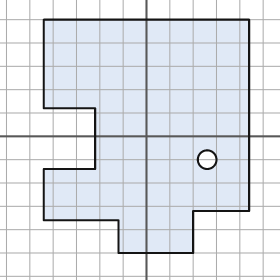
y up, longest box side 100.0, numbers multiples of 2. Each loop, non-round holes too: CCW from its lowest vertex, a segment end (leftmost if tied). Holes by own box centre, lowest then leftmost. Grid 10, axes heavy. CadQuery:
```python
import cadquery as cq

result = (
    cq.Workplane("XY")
    .moveTo(-12.0, -50.0)
    .lineTo(20.0, -50.0)
    .lineTo(20.0, -32.0)
    .lineTo(44.0, -32.0)
    .lineTo(44.0, 50.0)
    .lineTo(-44.0, 50.0)
    .lineTo(-44.0, 12.0)
    .lineTo(-22.0, 12.0)
    .lineTo(-22.0, -14.0)
    .lineTo(-44.0, -14.0)
    .lineTo(-44.0, -36.0)
    .lineTo(-12.0, -36.0)
    .close()
    .moveTo(26.0, -10.0)
    .circle(4.0)
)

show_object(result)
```